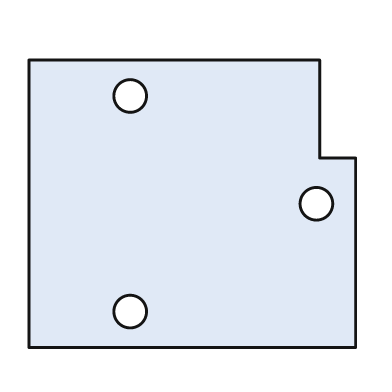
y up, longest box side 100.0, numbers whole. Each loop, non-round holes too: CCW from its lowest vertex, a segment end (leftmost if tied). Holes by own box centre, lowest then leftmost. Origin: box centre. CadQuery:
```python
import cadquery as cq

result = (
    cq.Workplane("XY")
    .moveTo(-50.0, -44.0)
    .lineTo(50.0, -44.0)
    .lineTo(50.0, 14.0)
    .lineTo(39.0, 14.0)
    .lineTo(39.0, 44.0)
    .lineTo(-50.0, 44.0)
    .close()
    .moveTo(-19.0, -33.0)
    .circle(5.0)
    .moveTo(38.0, 0.0)
    .circle(5.0)
    .moveTo(-19.0, 33.0)
    .circle(5.0)
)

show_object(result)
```